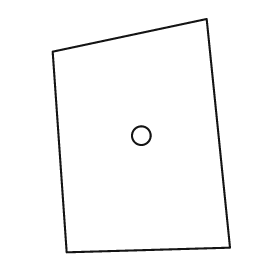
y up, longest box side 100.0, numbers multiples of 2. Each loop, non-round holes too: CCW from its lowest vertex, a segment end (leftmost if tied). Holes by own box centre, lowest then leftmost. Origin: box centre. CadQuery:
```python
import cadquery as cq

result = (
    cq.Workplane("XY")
    .moveTo(-32.0, -50.0)
    .lineTo(38.0, -48.0)
    .lineTo(28.0, 50.0)
    .lineTo(-38.0, 36.0)
    .close()
    .moveTo(0.0, 0.0)
    .circle(4.0)
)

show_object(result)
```